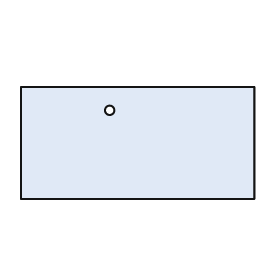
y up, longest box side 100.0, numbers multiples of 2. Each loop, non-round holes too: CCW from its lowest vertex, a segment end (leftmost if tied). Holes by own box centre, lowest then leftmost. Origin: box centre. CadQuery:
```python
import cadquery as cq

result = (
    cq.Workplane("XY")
    .moveTo(-50.0, -24.0)
    .lineTo(50.0, -24.0)
    .lineTo(50.0, 24.0)
    .lineTo(-50.0, 24.0)
    .close()
    .moveTo(-12.0, 14.0)
    .circle(2.0)
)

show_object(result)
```